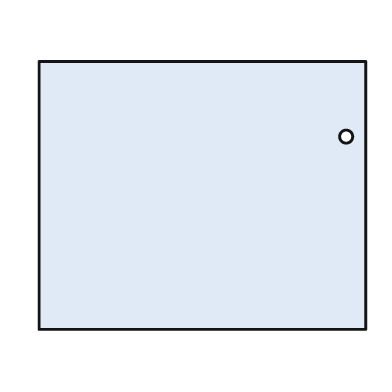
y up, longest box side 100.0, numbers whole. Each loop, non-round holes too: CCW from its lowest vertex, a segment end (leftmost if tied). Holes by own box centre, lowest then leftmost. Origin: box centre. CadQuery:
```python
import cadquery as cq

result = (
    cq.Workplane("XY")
    .moveTo(-50.0, -41.0)
    .lineTo(50.0, -41.0)
    .lineTo(50.0, 41.0)
    .lineTo(-50.0, 41.0)
    .close()
    .moveTo(44.0, 18.0)
    .circle(2.0)
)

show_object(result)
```